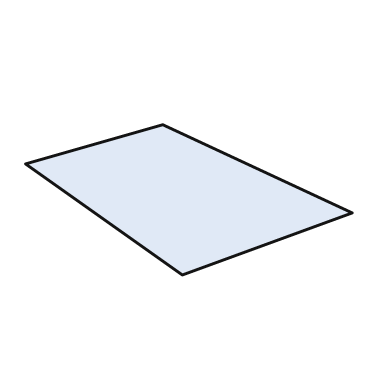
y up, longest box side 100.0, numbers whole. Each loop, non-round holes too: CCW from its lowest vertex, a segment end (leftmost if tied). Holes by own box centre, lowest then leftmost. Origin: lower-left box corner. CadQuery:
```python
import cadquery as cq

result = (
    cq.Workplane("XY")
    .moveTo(48.0, 0.0)
    .lineTo(100.0, 19.0)
    .lineTo(42.0, 46.0)
    .lineTo(0.0, 34.0)
    .close()
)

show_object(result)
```